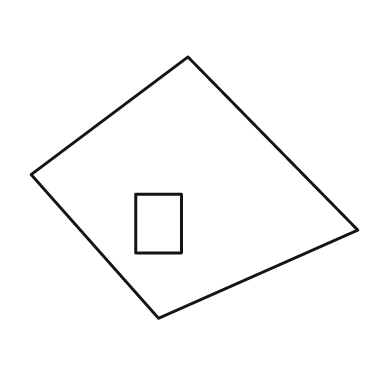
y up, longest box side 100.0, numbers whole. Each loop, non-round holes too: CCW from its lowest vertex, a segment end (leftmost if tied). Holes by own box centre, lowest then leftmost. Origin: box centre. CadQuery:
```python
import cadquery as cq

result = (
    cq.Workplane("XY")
    .moveTo(-11.0, -40.0)
    .lineTo(50.0, -13.0)
    .lineTo(-2.0, 40.0)
    .lineTo(-50.0, 4.0)
    .close()
    .moveTo(-18.0, -20.0)
    .lineTo(-4.0, -20.0)
    .lineTo(-4.0, -2.0)
    .lineTo(-18.0, -2.0)
    .close()
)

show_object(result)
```